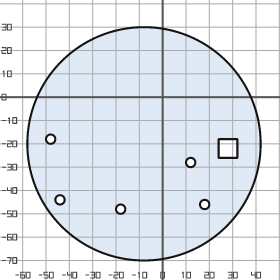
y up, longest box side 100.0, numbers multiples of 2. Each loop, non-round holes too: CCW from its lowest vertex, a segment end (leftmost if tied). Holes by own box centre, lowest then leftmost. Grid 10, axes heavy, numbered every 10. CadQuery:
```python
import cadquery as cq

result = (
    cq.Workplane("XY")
    .moveTo(-8.0, -20.0)
    .circle(50.0)
    .moveTo(-18.0, -48.0)
    .circle(2.0)
    .moveTo(18.0, -46.0)
    .circle(2.0)
    .moveTo(-44.0, -44.0)
    .circle(2.0)
    .moveTo(12.0, -28.0)
    .circle(2.0)
    .moveTo(24.0, -26.0)
    .lineTo(32.0, -26.0)
    .lineTo(32.0, -18.0)
    .lineTo(24.0, -18.0)
    .close()
    .moveTo(-48.0, -18.0)
    .circle(2.0)
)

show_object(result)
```